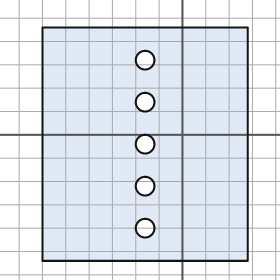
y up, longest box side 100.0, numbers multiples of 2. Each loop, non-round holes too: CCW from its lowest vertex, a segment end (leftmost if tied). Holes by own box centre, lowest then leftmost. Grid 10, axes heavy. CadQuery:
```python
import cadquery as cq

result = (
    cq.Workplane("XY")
    .moveTo(-60.0, -54.0)
    .lineTo(28.0, -54.0)
    .lineTo(28.0, 46.0)
    .lineTo(-60.0, 46.0)
    .close()
    .moveTo(-16.0, -40.0)
    .circle(4.0)
    .moveTo(-16.0, -22.0)
    .circle(4.0)
    .moveTo(-16.0, -4.0)
    .circle(4.0)
    .moveTo(-16.0, 14.0)
    .circle(4.0)
    .moveTo(-16.0, 32.0)
    .circle(4.0)
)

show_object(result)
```